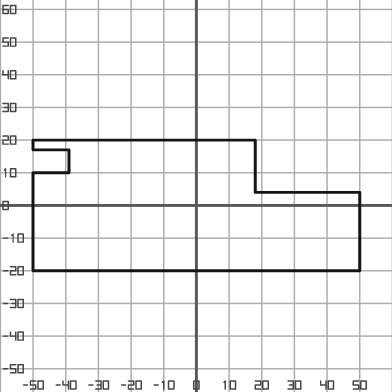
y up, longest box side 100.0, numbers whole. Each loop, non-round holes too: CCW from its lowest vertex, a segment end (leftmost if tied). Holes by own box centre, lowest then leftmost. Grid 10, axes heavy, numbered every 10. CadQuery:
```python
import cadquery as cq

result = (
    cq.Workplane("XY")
    .moveTo(-50.0, -20.0)
    .lineTo(50.0, -20.0)
    .lineTo(50.0, 4.0)
    .lineTo(18.0, 4.0)
    .lineTo(18.0, 20.0)
    .lineTo(-50.0, 20.0)
    .lineTo(-50.0, 17.0)
    .lineTo(-39.0, 17.0)
    .lineTo(-39.0, 10.0)
    .lineTo(-50.0, 10.0)
    .close()
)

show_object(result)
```